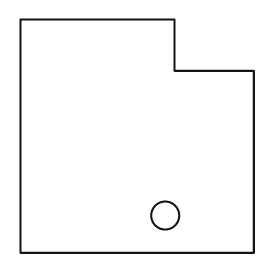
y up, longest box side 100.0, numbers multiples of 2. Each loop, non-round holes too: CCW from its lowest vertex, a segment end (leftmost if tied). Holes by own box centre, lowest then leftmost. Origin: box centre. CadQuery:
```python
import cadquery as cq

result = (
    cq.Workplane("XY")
    .moveTo(-50.0, -50.0)
    .lineTo(50.0, -50.0)
    .lineTo(50.0, 28.0)
    .lineTo(16.0, 28.0)
    .lineTo(16.0, 50.0)
    .lineTo(-50.0, 50.0)
    .close()
    .moveTo(12.0, -34.0)
    .circle(6.0)
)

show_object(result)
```